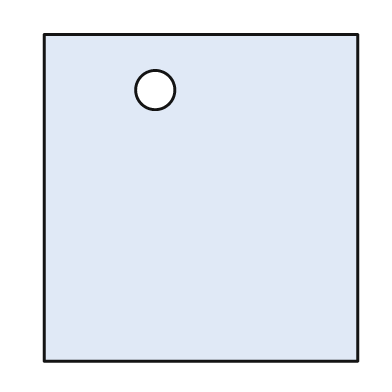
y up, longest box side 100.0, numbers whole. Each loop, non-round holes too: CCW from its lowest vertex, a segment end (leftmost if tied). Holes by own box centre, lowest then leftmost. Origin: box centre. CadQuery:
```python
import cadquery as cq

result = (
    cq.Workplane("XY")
    .moveTo(-48.0, -50.0)
    .lineTo(48.0, -50.0)
    .lineTo(48.0, 50.0)
    .lineTo(-48.0, 50.0)
    .close()
    .moveTo(-14.0, 33.0)
    .circle(6.0)
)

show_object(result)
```